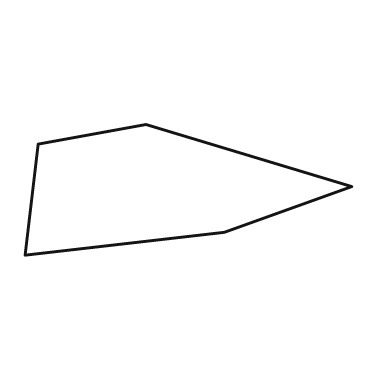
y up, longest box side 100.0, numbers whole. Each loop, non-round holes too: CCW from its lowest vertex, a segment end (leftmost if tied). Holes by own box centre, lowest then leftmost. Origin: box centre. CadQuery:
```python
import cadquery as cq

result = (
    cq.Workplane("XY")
    .moveTo(-50.0, -20.0)
    .lineTo(11.0, -13.0)
    .lineTo(50.0, 1.0)
    .lineTo(-13.0, 20.0)
    .lineTo(-46.0, 14.0)
    .close()
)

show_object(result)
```